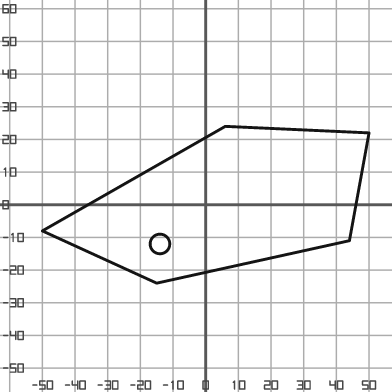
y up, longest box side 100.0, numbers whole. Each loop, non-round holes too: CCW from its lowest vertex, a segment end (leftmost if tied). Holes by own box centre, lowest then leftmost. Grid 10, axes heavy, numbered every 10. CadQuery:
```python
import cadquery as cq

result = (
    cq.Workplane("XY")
    .moveTo(-15.0, -24.0)
    .lineTo(44.0, -11.0)
    .lineTo(50.0, 22.0)
    .lineTo(6.0, 24.0)
    .lineTo(-50.0, -8.0)
    .close()
    .moveTo(-14.0, -12.0)
    .circle(3.0)
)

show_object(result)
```